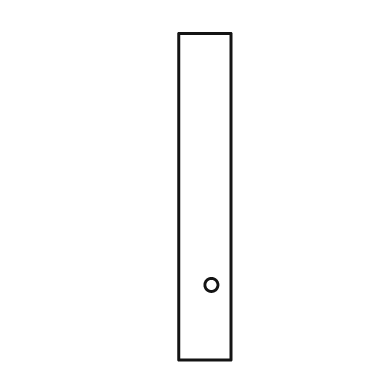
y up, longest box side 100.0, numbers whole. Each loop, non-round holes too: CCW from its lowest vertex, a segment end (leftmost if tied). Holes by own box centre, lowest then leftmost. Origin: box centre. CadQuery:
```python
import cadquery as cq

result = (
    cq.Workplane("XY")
    .moveTo(-8.0, -50.0)
    .lineTo(8.0, -50.0)
    .lineTo(8.0, 50.0)
    .lineTo(-8.0, 50.0)
    .close()
    .moveTo(2.0, -27.0)
    .circle(2.0)
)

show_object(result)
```